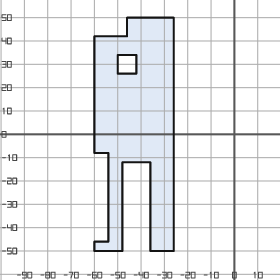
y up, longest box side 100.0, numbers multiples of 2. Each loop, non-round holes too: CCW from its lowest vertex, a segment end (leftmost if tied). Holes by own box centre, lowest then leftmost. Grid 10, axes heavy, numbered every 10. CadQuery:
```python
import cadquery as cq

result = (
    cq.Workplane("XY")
    .moveTo(-60.0, -50.0)
    .lineTo(-48.0, -50.0)
    .lineTo(-48.0, -12.0)
    .lineTo(-36.0, -12.0)
    .lineTo(-36.0, -50.0)
    .lineTo(-26.0, -50.0)
    .lineTo(-26.0, 50.0)
    .lineTo(-46.0, 50.0)
    .lineTo(-46.0, 42.0)
    .lineTo(-60.0, 42.0)
    .lineTo(-60.0, -8.0)
    .lineTo(-54.0, -8.0)
    .lineTo(-54.0, -46.0)
    .lineTo(-60.0, -46.0)
    .close()
    .moveTo(-50.0, 26.0)
    .lineTo(-42.0, 26.0)
    .lineTo(-42.0, 34.0)
    .lineTo(-50.0, 34.0)
    .close()
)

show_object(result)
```